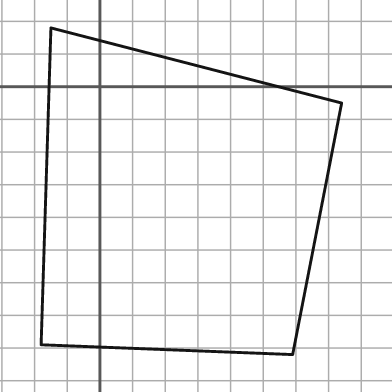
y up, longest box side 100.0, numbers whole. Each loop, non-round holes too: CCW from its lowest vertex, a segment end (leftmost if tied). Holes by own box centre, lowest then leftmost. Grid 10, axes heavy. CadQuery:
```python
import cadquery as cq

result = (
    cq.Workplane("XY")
    .moveTo(59.0, -82.0)
    .lineTo(74.0, -5.0)
    .lineTo(-15.0, 18.0)
    .lineTo(-18.0, -79.0)
    .close()
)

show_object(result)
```